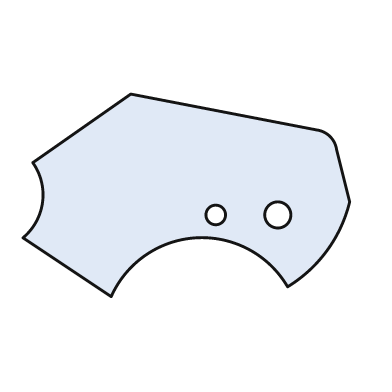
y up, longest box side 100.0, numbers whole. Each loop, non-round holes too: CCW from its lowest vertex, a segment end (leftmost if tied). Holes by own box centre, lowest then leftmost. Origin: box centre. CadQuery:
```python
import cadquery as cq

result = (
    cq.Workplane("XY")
    .moveTo(-23.0, -31.0)
    .threePointArc((3.0, -13.0), (31.0, -28.0))
    .threePointArc((43.0, -17.0), (50.0, -2.0))
    .lineTo(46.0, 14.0)
    .threePointArc((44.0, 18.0), (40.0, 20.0))
    .lineTo(-17.0, 31.0)
    .lineTo(-47.0, 10.0)
    .threePointArc((-44.0, -2.0), (-50.0, -13.0))
    .close()
    .moveTo(9.0, -6.0)
    .circle(3.0)
    .moveTo(28.0, -6.0)
    .circle(4.0)
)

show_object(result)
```